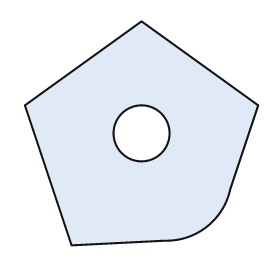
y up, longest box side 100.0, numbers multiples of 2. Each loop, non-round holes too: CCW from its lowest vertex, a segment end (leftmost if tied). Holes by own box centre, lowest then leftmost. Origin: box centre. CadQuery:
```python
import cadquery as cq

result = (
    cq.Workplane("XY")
    .moveTo(-30.0, -48.0)
    .lineTo(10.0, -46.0)
    .threePointArc((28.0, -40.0), (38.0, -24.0))
    .lineTo(50.0, 12.0)
    .lineTo(0.0, 48.0)
    .lineTo(-50.0, 12.0)
    .close()
    .moveTo(0.0, 0.0)
    .circle(12.0)
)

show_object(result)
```